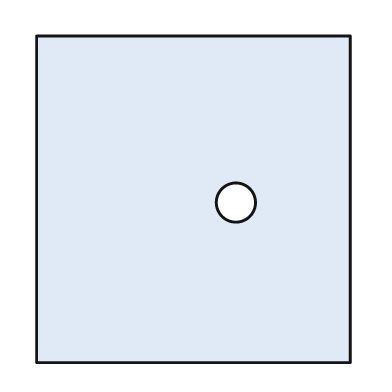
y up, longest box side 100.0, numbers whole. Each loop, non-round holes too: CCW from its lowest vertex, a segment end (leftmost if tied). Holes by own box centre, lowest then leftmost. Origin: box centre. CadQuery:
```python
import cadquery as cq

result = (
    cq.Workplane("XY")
    .moveTo(-48.0, -50.0)
    .lineTo(48.0, -50.0)
    .lineTo(48.0, 50.0)
    .lineTo(-48.0, 50.0)
    .close()
    .moveTo(13.0, -1.0)
    .circle(6.0)
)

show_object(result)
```